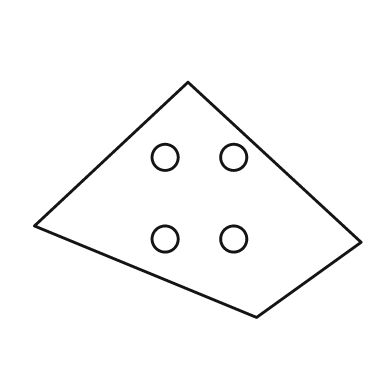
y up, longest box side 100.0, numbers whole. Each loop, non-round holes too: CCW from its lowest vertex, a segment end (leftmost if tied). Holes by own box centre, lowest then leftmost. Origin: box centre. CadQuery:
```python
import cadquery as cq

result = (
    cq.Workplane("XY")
    .moveTo(18.0, -36.0)
    .lineTo(50.0, -13.0)
    .lineTo(-3.0, 36.0)
    .lineTo(-50.0, -8.0)
    .close()
    .moveTo(-10.0, -12.0)
    .circle(4.0)
    .moveTo(11.0, -12.0)
    .circle(4.0)
    .moveTo(-10.0, 13.0)
    .circle(4.0)
    .moveTo(11.0, 13.0)
    .circle(4.0)
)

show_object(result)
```